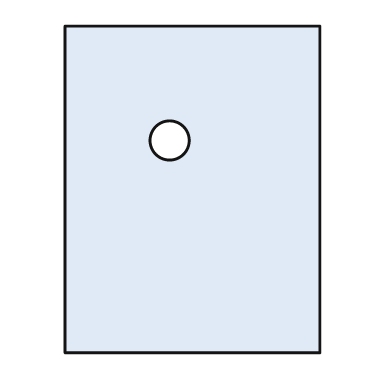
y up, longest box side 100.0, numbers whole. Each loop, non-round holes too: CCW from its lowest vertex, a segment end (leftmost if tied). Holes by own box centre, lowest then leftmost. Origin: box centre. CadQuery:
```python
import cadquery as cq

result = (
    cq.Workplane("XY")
    .moveTo(-39.0, -50.0)
    .lineTo(39.0, -50.0)
    .lineTo(39.0, 50.0)
    .lineTo(-39.0, 50.0)
    .close()
    .moveTo(-7.0, 15.0)
    .circle(6.0)
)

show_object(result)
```